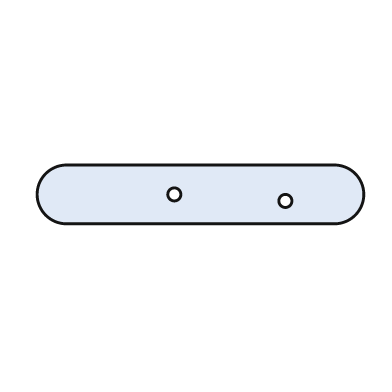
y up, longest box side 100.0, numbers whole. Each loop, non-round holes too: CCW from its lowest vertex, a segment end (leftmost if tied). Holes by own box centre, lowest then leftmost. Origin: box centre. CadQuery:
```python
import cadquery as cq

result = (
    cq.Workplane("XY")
    .moveTo(-41.0, -9.0)
    .lineTo(41.0, -9.0)
    .threePointArc((50.0, 0.0), (41.0, 9.0))
    .lineTo(-41.0, 9.0)
    .threePointArc((-50.0, 0.0), (-41.0, -9.0))
    .close()
    .moveTo(26.0, -2.0)
    .circle(2.0)
    .moveTo(-8.0, 0.0)
    .circle(2.0)
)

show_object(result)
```